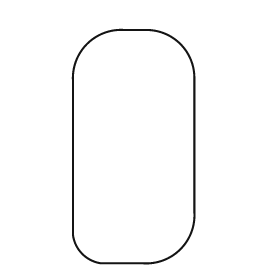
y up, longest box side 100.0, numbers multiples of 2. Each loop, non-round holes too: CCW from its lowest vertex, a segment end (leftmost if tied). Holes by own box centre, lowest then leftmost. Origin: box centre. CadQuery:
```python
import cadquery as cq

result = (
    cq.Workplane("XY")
    .moveTo(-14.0, -50.0)
    .lineTo(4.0, -50.0)
    .threePointArc((20.0, -44.0), (26.0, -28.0))
    .lineTo(26.0, 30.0)
    .threePointArc((20.0, 44.0), (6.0, 50.0))
    .lineTo(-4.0, 50.0)
    .threePointArc((-20.0, 44.0), (-26.0, 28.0))
    .lineTo(-26.0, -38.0)
    .threePointArc((-22.0, -46.0), (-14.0, -50.0))
    .close()
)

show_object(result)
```